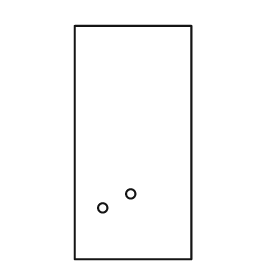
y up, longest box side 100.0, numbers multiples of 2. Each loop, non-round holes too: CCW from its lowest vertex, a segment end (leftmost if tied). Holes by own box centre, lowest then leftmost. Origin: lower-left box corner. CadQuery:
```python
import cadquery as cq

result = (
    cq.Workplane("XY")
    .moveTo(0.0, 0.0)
    .lineTo(50.0, 0.0)
    .lineTo(50.0, 100.0)
    .lineTo(0.0, 100.0)
    .close()
    .moveTo(12.0, 22.0)
    .circle(2.0)
    .moveTo(24.0, 28.0)
    .circle(2.0)
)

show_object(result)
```